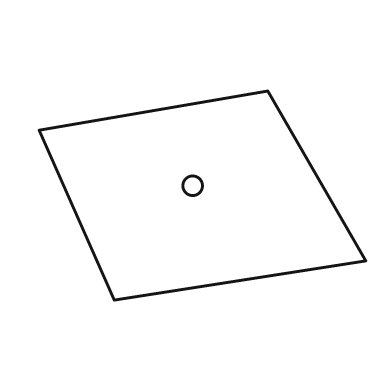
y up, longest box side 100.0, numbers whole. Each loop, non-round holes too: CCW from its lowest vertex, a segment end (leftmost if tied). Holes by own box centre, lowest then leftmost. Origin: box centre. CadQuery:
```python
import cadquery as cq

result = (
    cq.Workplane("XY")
    .moveTo(-27.0, -32.0)
    .lineTo(50.0, -20.0)
    .lineTo(20.0, 32.0)
    .lineTo(-50.0, 20.0)
    .close()
    .moveTo(-3.0, 3.0)
    .circle(3.0)
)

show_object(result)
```